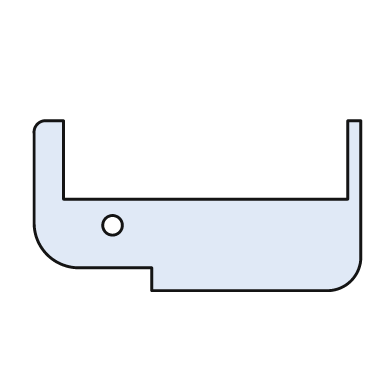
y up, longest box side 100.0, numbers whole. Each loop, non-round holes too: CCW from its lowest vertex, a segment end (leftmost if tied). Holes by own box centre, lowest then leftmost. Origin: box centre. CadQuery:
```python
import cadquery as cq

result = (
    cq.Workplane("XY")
    .moveTo(-14.0, -26.0)
    .lineTo(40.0, -26.0)
    .threePointArc((47.0, -23.0), (50.0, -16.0))
    .lineTo(50.0, 26.0)
    .lineTo(46.0, 26.0)
    .lineTo(46.0, 2.0)
    .lineTo(-41.0, 2.0)
    .lineTo(-41.0, 26.0)
    .lineTo(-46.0, 26.0)
    .threePointArc((-49.0, 25.0), (-50.0, 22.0))
    .lineTo(-50.0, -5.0)
    .threePointArc((-46.0, -15.0), (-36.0, -19.0))
    .lineTo(-14.0, -19.0)
    .close()
    .moveTo(-26.0, -6.0)
    .circle(3.0)
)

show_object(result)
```